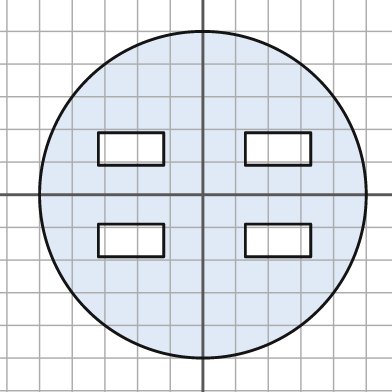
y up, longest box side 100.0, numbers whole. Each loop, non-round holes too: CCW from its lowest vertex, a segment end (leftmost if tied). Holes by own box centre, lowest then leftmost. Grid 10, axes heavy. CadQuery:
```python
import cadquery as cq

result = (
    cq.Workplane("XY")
    .moveTo(0.0, 0.0)
    .circle(50.0)
    .moveTo(-32.0, -19.0)
    .lineTo(-12.0, -19.0)
    .lineTo(-12.0, -9.0)
    .lineTo(-32.0, -9.0)
    .close()
    .moveTo(13.0, -19.0)
    .lineTo(33.0, -19.0)
    .lineTo(33.0, -9.0)
    .lineTo(13.0, -9.0)
    .close()
    .moveTo(-32.0, 9.0)
    .lineTo(-12.0, 9.0)
    .lineTo(-12.0, 19.0)
    .lineTo(-32.0, 19.0)
    .close()
    .moveTo(13.0, 9.0)
    .lineTo(33.0, 9.0)
    .lineTo(33.0, 19.0)
    .lineTo(13.0, 19.0)
    .close()
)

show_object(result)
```